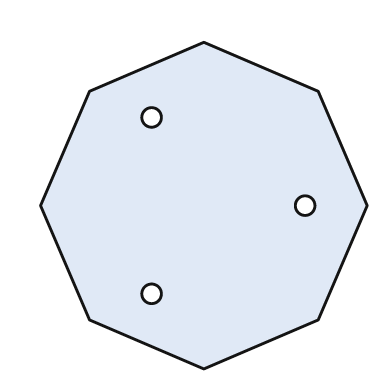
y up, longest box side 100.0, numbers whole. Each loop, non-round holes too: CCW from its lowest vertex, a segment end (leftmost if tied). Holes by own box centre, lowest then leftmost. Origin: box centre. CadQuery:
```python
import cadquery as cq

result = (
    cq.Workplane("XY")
    .moveTo(0.0, -50.0)
    .lineTo(35.0, -35.0)
    .lineTo(50.0, 0.0)
    .lineTo(35.0, 35.0)
    .lineTo(0.0, 50.0)
    .lineTo(-35.0, 35.0)
    .lineTo(-50.0, 0.0)
    .lineTo(-35.0, -35.0)
    .close()
    .moveTo(-16.0, -27.0)
    .circle(3.0)
    .moveTo(31.0, 0.0)
    .circle(3.0)
    .moveTo(-16.0, 27.0)
    .circle(3.0)
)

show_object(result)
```